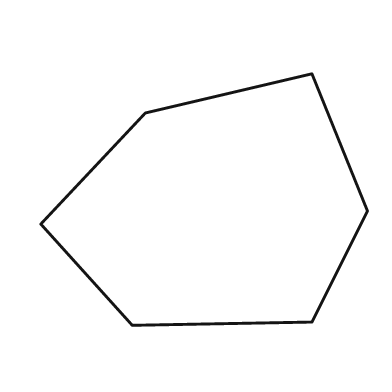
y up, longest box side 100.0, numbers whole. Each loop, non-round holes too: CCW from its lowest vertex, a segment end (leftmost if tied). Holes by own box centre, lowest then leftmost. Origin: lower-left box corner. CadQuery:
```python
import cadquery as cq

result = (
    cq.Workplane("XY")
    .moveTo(28.0, 0.0)
    .lineTo(83.0, 1.0)
    .lineTo(100.0, 35.0)
    .lineTo(83.0, 77.0)
    .lineTo(32.0, 65.0)
    .lineTo(0.0, 31.0)
    .close()
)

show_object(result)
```